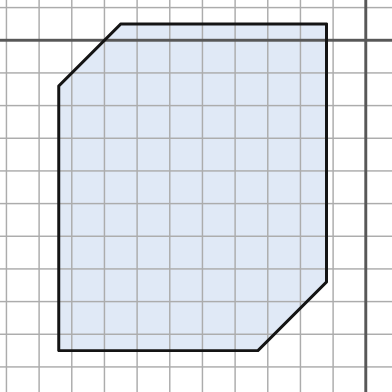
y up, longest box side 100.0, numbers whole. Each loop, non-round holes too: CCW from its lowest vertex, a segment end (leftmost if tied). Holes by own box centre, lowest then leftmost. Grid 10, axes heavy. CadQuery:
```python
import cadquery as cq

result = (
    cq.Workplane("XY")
    .moveTo(-94.0, -95.0)
    .lineTo(-33.0, -95.0)
    .lineTo(-12.0, -74.0)
    .lineTo(-12.0, 5.0)
    .lineTo(-75.0, 5.0)
    .lineTo(-94.0, -14.0)
    .close()
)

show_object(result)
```